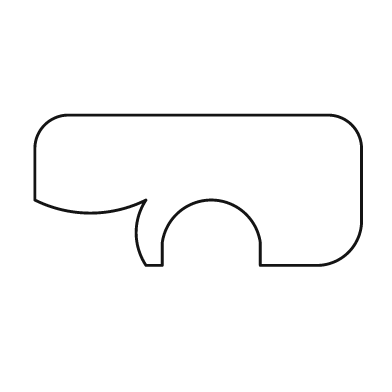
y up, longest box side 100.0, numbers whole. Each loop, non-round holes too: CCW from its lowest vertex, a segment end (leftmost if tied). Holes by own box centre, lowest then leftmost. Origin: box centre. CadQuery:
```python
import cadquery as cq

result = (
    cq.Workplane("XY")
    .moveTo(-16.0, -23.0)
    .lineTo(-11.0, -23.0)
    .lineTo(-11.0, -16.0)
    .threePointArc((4.0, -3.0), (19.0, -16.0))
    .lineTo(19.0, -23.0)
    .lineTo(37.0, -23.0)
    .threePointArc((46.0, -19.0), (50.0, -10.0))
    .lineTo(50.0, 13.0)
    .threePointArc((47.0, 20.0), (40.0, 23.0))
    .lineTo(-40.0, 23.0)
    .threePointArc((-47.0, 20.0), (-50.0, 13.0))
    .lineTo(-50.0, -3.0)
    .threePointArc((-33.0, -7.0), (-16.0, -3.0))
    .threePointArc((-19.0, -13.0), (-16.0, -23.0))
    .close()
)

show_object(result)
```